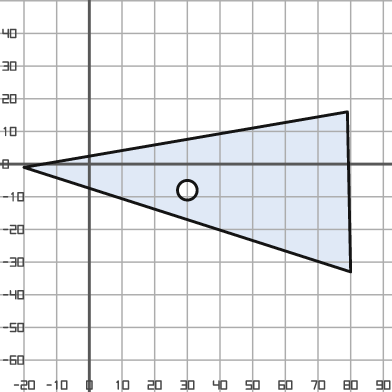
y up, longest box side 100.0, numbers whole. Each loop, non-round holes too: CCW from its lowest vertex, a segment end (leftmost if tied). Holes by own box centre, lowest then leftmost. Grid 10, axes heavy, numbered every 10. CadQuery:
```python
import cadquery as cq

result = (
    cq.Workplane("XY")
    .moveTo(80.0, -33.0)
    .lineTo(79.0, 16.0)
    .lineTo(-20.0, -1.0)
    .close()
    .moveTo(30.0, -8.0)
    .circle(3.0)
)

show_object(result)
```